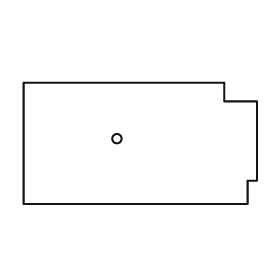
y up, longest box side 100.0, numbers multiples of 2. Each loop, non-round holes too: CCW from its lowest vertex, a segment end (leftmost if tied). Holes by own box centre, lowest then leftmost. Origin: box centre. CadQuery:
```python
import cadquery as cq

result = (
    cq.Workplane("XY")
    .moveTo(-50.0, -26.0)
    .lineTo(46.0, -26.0)
    .lineTo(46.0, -16.0)
    .lineTo(50.0, -16.0)
    .lineTo(50.0, 18.0)
    .lineTo(36.0, 18.0)
    .lineTo(36.0, 26.0)
    .lineTo(-50.0, 26.0)
    .close()
    .moveTo(-10.0, 2.0)
    .circle(2.0)
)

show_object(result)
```